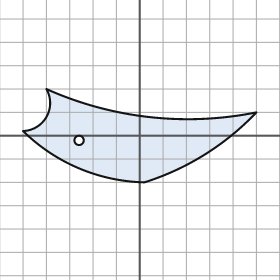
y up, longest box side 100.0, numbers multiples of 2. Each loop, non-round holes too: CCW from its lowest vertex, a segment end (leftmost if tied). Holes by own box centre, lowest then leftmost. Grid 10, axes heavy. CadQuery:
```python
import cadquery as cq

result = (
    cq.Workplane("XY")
    .moveTo(2.0, -20.0)
    .threePointArc((28.0, -8.0), (50.0, 10.0))
    .threePointArc((4.0, 8.0), (-40.0, 20.0))
    .threePointArc((-40.0, 8.0), (-50.0, 2.0))
    .threePointArc((-26.0, -14.0), (2.0, -20.0))
    .close()
    .moveTo(-26.0, -2.0)
    .circle(2.0)
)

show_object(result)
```